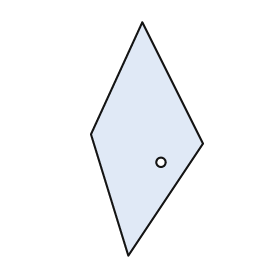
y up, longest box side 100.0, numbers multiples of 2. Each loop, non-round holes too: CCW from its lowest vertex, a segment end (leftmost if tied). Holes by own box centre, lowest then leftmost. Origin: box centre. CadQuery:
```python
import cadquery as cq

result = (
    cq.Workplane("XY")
    .moveTo(-8.0, -50.0)
    .lineTo(24.0, -2.0)
    .lineTo(-2.0, 50.0)
    .lineTo(-24.0, 2.0)
    .close()
    .moveTo(6.0, -10.0)
    .circle(2.0)
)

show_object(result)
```